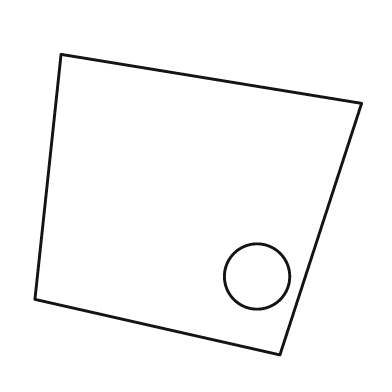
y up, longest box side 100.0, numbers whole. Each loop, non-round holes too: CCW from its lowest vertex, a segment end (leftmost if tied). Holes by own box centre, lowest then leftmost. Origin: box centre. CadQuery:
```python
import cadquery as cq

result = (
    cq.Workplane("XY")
    .moveTo(25.0, -46.0)
    .lineTo(50.0, 31.0)
    .lineTo(-42.0, 46.0)
    .lineTo(-50.0, -29.0)
    .close()
    .moveTo(18.0, -22.0)
    .circle(10.0)
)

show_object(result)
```